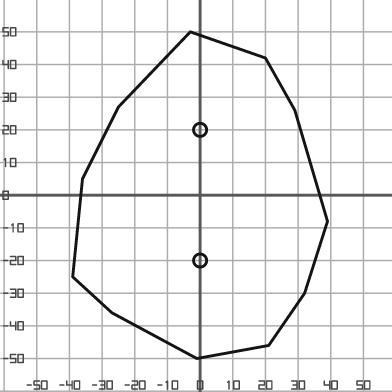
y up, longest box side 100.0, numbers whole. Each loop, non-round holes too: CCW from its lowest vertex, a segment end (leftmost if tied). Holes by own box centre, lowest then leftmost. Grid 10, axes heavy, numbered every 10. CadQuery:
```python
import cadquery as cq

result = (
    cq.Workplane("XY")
    .moveTo(-1.0, -50.0)
    .lineTo(21.0, -46.0)
    .lineTo(32.0, -30.0)
    .lineTo(39.0, -8.0)
    .lineTo(29.0, 26.0)
    .lineTo(20.0, 42.0)
    .lineTo(-3.0, 50.0)
    .lineTo(-25.0, 27.0)
    .lineTo(-36.0, 5.0)
    .lineTo(-39.0, -25.0)
    .lineTo(-27.0, -36.0)
    .close()
    .moveTo(0.0, -20.0)
    .circle(2.0)
    .moveTo(0.0, 20.0)
    .circle(2.0)
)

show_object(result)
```